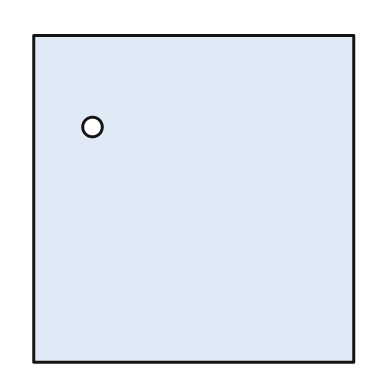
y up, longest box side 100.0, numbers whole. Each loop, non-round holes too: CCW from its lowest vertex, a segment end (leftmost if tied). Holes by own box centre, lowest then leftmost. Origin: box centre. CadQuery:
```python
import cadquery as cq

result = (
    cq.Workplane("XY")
    .moveTo(-49.0, -50.0)
    .lineTo(49.0, -50.0)
    .lineTo(49.0, 50.0)
    .lineTo(-49.0, 50.0)
    .close()
    .moveTo(-31.0, 22.0)
    .circle(3.0)
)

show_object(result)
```